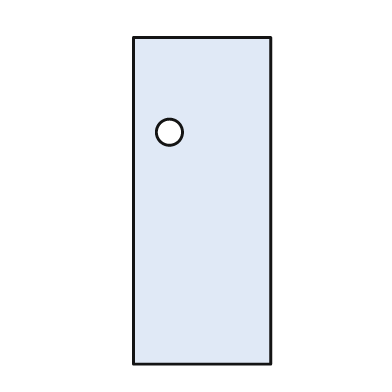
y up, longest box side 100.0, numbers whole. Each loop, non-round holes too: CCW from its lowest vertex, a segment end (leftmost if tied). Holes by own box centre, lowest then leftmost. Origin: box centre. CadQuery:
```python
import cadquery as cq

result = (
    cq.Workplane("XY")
    .moveTo(-21.0, -50.0)
    .lineTo(21.0, -50.0)
    .lineTo(21.0, 50.0)
    .lineTo(-21.0, 50.0)
    .close()
    .moveTo(-10.0, 21.0)
    .circle(4.0)
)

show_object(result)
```